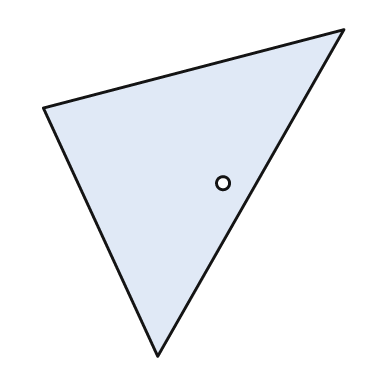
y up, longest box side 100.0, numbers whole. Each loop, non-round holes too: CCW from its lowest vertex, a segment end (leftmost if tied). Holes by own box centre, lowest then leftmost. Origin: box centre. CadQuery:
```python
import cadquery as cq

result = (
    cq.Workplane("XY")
    .moveTo(-11.0, -50.0)
    .lineTo(46.0, 50.0)
    .lineTo(-46.0, 26.0)
    .close()
    .moveTo(9.0, 3.0)
    .circle(2.0)
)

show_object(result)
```